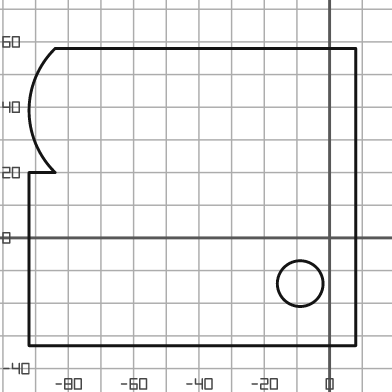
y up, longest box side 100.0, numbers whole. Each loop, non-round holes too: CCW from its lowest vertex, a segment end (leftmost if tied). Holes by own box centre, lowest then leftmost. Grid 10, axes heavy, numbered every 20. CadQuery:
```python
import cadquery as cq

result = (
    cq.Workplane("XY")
    .moveTo(-92.0, -33.0)
    .lineTo(8.0, -33.0)
    .lineTo(8.0, 58.0)
    .lineTo(-84.0, 58.0)
    .threePointArc((-92.0, 39.0), (-84.0, 20.0))
    .lineTo(-92.0, 20.0)
    .close()
    .moveTo(-9.0, -14.0)
    .circle(7.0)
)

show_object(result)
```